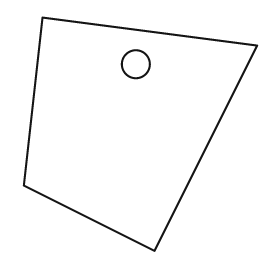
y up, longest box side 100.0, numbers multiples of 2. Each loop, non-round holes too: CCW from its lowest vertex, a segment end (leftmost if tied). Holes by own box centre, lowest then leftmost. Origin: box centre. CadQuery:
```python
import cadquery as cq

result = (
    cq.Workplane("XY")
    .moveTo(6.0, -50.0)
    .lineTo(50.0, 38.0)
    .lineTo(-42.0, 50.0)
    .lineTo(-50.0, -22.0)
    .close()
    .moveTo(-2.0, 30.0)
    .circle(6.0)
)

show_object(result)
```